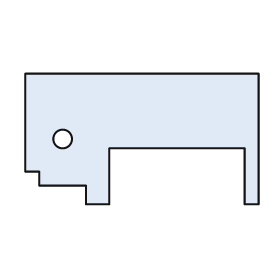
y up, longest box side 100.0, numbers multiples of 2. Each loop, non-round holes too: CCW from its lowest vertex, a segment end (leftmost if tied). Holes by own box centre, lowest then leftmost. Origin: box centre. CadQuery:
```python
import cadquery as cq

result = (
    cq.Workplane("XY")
    .moveTo(-24.0, -28.0)
    .lineTo(-14.0, -28.0)
    .lineTo(-14.0, -4.0)
    .lineTo(44.0, -4.0)
    .lineTo(44.0, -28.0)
    .lineTo(50.0, -28.0)
    .lineTo(50.0, 28.0)
    .lineTo(-50.0, 28.0)
    .lineTo(-50.0, -14.0)
    .lineTo(-44.0, -14.0)
    .lineTo(-44.0, -20.0)
    .lineTo(-24.0, -20.0)
    .close()
    .moveTo(-34.0, 0.0)
    .circle(4.0)
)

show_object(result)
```